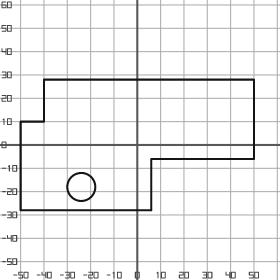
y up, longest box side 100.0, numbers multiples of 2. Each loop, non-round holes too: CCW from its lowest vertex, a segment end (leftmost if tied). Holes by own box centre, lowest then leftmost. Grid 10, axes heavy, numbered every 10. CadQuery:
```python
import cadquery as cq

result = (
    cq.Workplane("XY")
    .moveTo(-50.0, -28.0)
    .lineTo(6.0, -28.0)
    .lineTo(6.0, -6.0)
    .lineTo(50.0, -6.0)
    .lineTo(50.0, 28.0)
    .lineTo(-40.0, 28.0)
    .lineTo(-40.0, 10.0)
    .lineTo(-50.0, 10.0)
    .close()
    .moveTo(-24.0, -18.0)
    .circle(6.0)
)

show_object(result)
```